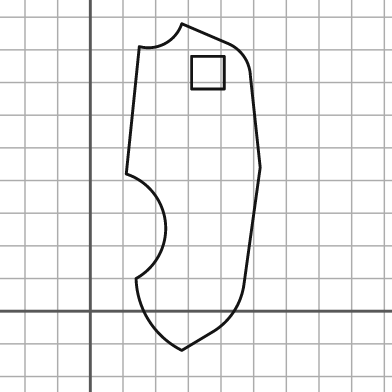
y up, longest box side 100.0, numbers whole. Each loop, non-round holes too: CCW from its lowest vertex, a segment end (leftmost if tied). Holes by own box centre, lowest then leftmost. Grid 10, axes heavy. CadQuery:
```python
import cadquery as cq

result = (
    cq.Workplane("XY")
    .moveTo(28.0, -12.0)
    .lineTo(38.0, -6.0)
    .threePointArc((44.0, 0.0), (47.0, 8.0))
    .lineTo(52.0, 44.0)
    .lineTo(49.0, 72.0)
    .threePointArc((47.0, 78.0), (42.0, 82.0))
    .lineTo(28.0, 88.0)
    .threePointArc((23.0, 82.0), (15.0, 81.0))
    .lineTo(11.0, 42.0)
    .threePointArc((23.0, 27.0), (14.0, 10.0))
    .threePointArc((18.0, -3.0), (28.0, -12.0))
    .close()
    .moveTo(31.0, 68.0)
    .lineTo(41.0, 68.0)
    .lineTo(41.0, 78.0)
    .lineTo(31.0, 78.0)
    .close()
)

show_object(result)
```